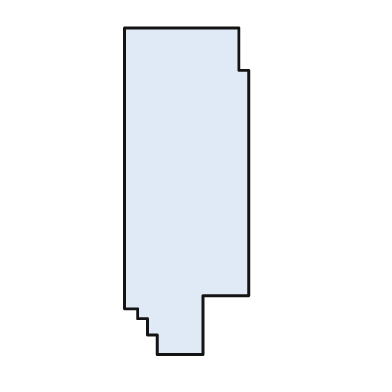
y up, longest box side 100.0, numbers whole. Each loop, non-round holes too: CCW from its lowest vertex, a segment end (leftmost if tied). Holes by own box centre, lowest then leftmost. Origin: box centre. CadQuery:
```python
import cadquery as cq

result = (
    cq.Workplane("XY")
    .moveTo(-9.0, -50.0)
    .lineTo(5.0, -50.0)
    .lineTo(5.0, -32.0)
    .lineTo(19.0, -32.0)
    .lineTo(19.0, 37.0)
    .lineTo(16.0, 37.0)
    .lineTo(16.0, 50.0)
    .lineTo(-19.0, 50.0)
    .lineTo(-19.0, -36.0)
    .lineTo(-15.0, -36.0)
    .lineTo(-15.0, -39.0)
    .lineTo(-12.0, -39.0)
    .lineTo(-12.0, -44.0)
    .lineTo(-9.0, -44.0)
    .close()
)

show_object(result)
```